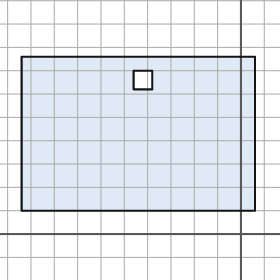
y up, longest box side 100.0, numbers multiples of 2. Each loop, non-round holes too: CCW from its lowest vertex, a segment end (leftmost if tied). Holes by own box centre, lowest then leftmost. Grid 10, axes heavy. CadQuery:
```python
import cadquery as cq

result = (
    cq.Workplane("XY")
    .moveTo(-94.0, 10.0)
    .lineTo(6.0, 10.0)
    .lineTo(6.0, 76.0)
    .lineTo(-94.0, 76.0)
    .close()
    .moveTo(-46.0, 62.0)
    .lineTo(-38.0, 62.0)
    .lineTo(-38.0, 70.0)
    .lineTo(-46.0, 70.0)
    .close()
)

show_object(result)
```